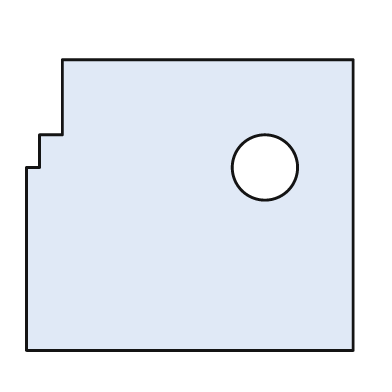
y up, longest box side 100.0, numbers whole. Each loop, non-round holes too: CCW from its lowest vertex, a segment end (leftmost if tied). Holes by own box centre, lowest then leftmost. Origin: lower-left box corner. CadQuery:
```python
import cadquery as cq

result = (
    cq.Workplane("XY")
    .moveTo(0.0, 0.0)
    .lineTo(100.0, 0.0)
    .lineTo(100.0, 89.0)
    .lineTo(11.0, 89.0)
    .lineTo(11.0, 66.0)
    .lineTo(4.0, 66.0)
    .lineTo(4.0, 56.0)
    .lineTo(0.0, 56.0)
    .close()
    .moveTo(73.0, 56.0)
    .circle(10.0)
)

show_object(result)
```